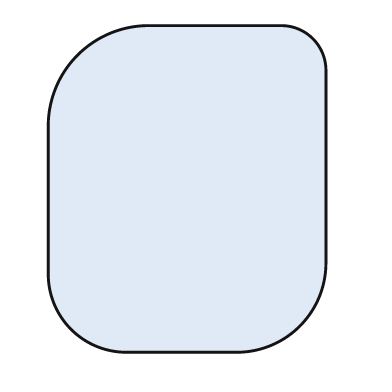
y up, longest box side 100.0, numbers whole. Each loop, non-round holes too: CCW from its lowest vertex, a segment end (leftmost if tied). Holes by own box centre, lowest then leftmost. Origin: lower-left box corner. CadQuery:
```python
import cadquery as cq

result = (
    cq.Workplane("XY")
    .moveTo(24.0, 0.0)
    .lineTo(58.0, 0.0)
    .threePointArc((77.0, 8.0), (85.0, 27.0))
    .lineTo(85.0, 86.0)
    .threePointArc((81.0, 96.0), (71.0, 100.0))
    .lineTo(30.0, 100.0)
    .threePointArc((9.0, 91.0), (0.0, 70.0))
    .lineTo(0.0, 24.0)
    .threePointArc((7.0, 7.0), (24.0, 0.0))
    .close()
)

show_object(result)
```